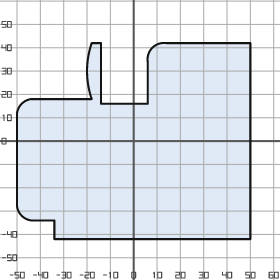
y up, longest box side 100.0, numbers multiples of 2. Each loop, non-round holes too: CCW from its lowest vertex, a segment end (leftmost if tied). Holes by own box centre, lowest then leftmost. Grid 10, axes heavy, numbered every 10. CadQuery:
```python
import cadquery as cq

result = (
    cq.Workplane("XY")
    .moveTo(-34.0, -42.0)
    .lineTo(50.0, -42.0)
    .lineTo(50.0, 42.0)
    .lineTo(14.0, 42.0)
    .threePointArc((8.0, 40.0), (6.0, 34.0))
    .lineTo(6.0, 16.0)
    .lineTo(-14.0, 16.0)
    .lineTo(-14.0, 42.0)
    .lineTo(-18.0, 42.0)
    .threePointArc((-20.0, 30.0), (-18.0, 18.0))
    .lineTo(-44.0, 18.0)
    .threePointArc((-48.0, 16.0), (-50.0, 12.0))
    .lineTo(-50.0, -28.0)
    .threePointArc((-48.0, -32.0), (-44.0, -34.0))
    .lineTo(-34.0, -34.0)
    .close()
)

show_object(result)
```